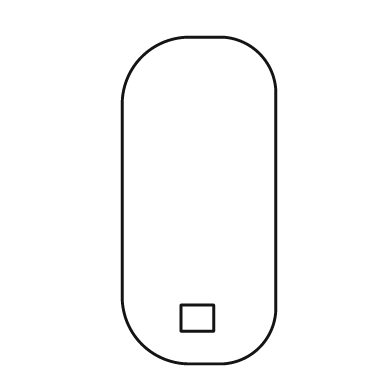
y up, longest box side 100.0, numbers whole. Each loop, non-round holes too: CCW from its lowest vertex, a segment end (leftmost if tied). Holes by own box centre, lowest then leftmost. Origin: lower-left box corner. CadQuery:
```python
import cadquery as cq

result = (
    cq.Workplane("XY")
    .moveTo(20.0, 0.0)
    .lineTo(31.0, 0.0)
    .threePointArc((42.0, 5.0), (47.0, 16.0))
    .lineTo(47.0, 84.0)
    .threePointArc((42.0, 95.0), (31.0, 100.0))
    .lineTo(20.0, 100.0)
    .threePointArc((6.0, 94.0), (0.0, 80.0))
    .lineTo(0.0, 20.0)
    .threePointArc((6.0, 6.0), (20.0, 0.0))
    .close()
    .moveTo(18.0, 10.0)
    .lineTo(28.0, 10.0)
    .lineTo(28.0, 18.0)
    .lineTo(18.0, 18.0)
    .close()
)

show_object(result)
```